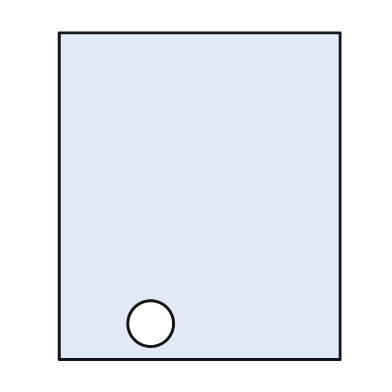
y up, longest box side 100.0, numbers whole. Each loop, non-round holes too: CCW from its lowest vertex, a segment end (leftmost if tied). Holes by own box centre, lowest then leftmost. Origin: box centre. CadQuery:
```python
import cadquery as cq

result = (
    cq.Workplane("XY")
    .moveTo(-43.0, -50.0)
    .lineTo(43.0, -50.0)
    .lineTo(43.0, 50.0)
    .lineTo(-43.0, 50.0)
    .close()
    .moveTo(-15.0, -39.0)
    .circle(7.0)
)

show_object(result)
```